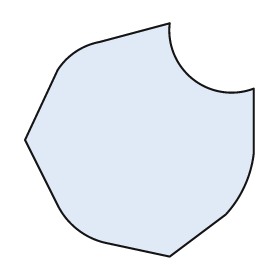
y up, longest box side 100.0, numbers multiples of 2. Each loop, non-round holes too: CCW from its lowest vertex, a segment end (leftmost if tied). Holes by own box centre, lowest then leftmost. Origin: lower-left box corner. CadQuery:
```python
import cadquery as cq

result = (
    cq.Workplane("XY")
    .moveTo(62.0, 0.0)
    .lineTo(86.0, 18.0)
    .threePointArc((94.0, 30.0), (98.0, 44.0))
    .lineTo(98.0, 72.0)
    .threePointArc((72.0, 76.0), (62.0, 100.0))
    .lineTo(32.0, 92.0)
    .threePointArc((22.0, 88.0), (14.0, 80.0))
    .lineTo(0.0, 50.0)
    .lineTo(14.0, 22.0)
    .threePointArc((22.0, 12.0), (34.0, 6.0))
    .close()
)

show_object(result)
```